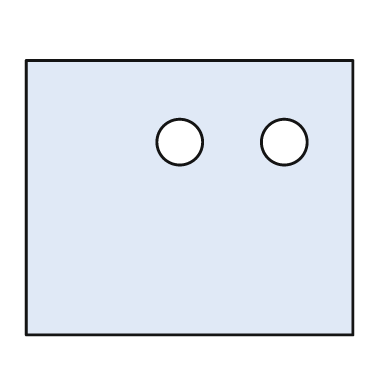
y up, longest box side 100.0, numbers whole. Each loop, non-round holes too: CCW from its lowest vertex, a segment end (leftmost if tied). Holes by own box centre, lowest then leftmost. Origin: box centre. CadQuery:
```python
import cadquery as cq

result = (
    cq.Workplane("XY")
    .moveTo(-50.0, -42.0)
    .lineTo(50.0, -42.0)
    .lineTo(50.0, 42.0)
    .lineTo(-50.0, 42.0)
    .close()
    .moveTo(-3.0, 17.0)
    .circle(7.0)
    .moveTo(29.0, 17.0)
    .circle(7.0)
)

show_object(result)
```